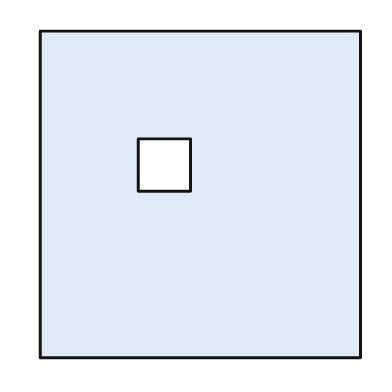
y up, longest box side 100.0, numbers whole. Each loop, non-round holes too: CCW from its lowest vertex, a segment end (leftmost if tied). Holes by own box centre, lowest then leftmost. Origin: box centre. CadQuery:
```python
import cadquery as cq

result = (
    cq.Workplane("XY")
    .moveTo(-49.0, -50.0)
    .lineTo(49.0, -50.0)
    .lineTo(49.0, 50.0)
    .lineTo(-49.0, 50.0)
    .close()
    .moveTo(-19.0, 1.0)
    .lineTo(-3.0, 1.0)
    .lineTo(-3.0, 17.0)
    .lineTo(-19.0, 17.0)
    .close()
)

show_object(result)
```